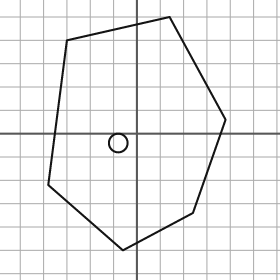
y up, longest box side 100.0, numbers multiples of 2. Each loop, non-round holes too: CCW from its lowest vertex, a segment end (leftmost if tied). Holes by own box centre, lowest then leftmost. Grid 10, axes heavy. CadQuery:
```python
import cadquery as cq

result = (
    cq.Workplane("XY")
    .moveTo(-6.0, -50.0)
    .lineTo(24.0, -34.0)
    .lineTo(38.0, 6.0)
    .lineTo(14.0, 50.0)
    .lineTo(-30.0, 40.0)
    .lineTo(-38.0, -22.0)
    .close()
    .moveTo(-8.0, -4.0)
    .circle(4.0)
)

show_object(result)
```